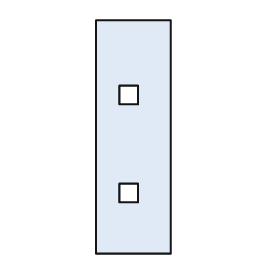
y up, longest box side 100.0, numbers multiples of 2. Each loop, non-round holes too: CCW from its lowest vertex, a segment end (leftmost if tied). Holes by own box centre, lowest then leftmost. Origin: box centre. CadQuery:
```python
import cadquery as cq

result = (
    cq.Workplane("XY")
    .moveTo(-16.0, -50.0)
    .lineTo(16.0, -50.0)
    .lineTo(16.0, 50.0)
    .lineTo(-16.0, 50.0)
    .close()
    .moveTo(-6.0, -28.0)
    .lineTo(2.0, -28.0)
    .lineTo(2.0, -20.0)
    .lineTo(-6.0, -20.0)
    .close()
    .moveTo(-6.0, 14.0)
    .lineTo(2.0, 14.0)
    .lineTo(2.0, 22.0)
    .lineTo(-6.0, 22.0)
    .close()
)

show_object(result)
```